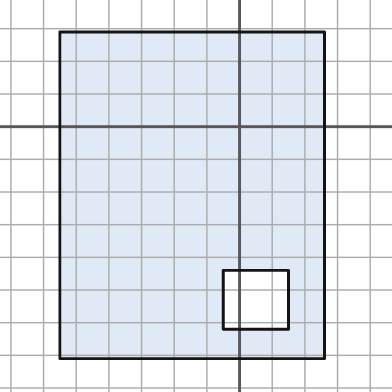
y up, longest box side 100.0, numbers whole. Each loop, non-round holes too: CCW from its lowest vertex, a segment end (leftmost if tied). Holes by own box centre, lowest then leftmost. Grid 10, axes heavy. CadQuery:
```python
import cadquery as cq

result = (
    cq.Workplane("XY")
    .moveTo(-55.0, -71.0)
    .lineTo(26.0, -71.0)
    .lineTo(26.0, 29.0)
    .lineTo(-55.0, 29.0)
    .close()
    .moveTo(-5.0, -62.0)
    .lineTo(15.0, -62.0)
    .lineTo(15.0, -44.0)
    .lineTo(-5.0, -44.0)
    .close()
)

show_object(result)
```